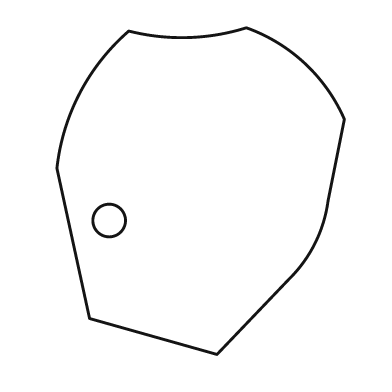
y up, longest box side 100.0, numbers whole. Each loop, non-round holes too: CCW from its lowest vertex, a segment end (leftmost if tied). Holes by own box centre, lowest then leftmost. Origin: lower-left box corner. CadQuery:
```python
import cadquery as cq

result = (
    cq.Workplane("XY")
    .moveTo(49.0, 0.0)
    .lineTo(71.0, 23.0)
    .threePointArc((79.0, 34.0), (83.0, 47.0))
    .lineTo(88.0, 72.0)
    .threePointArc((76.0, 89.0), (58.0, 100.0))
    .threePointArc((40.0, 97.0), (22.0, 99.0))
    .threePointArc((7.0, 80.0), (0.0, 57.0))
    .lineTo(10.0, 11.0)
    .close()
    .moveTo(16.0, 41.0)
    .circle(5.0)
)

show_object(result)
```